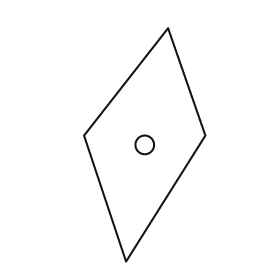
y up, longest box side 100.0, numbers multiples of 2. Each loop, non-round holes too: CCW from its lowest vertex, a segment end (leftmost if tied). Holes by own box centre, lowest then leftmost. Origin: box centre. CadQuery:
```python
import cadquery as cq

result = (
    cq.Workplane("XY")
    .moveTo(-8.0, -50.0)
    .lineTo(26.0, 4.0)
    .lineTo(10.0, 50.0)
    .lineTo(-26.0, 4.0)
    .close()
    .moveTo(0.0, 0.0)
    .circle(4.0)
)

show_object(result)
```